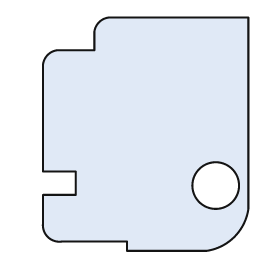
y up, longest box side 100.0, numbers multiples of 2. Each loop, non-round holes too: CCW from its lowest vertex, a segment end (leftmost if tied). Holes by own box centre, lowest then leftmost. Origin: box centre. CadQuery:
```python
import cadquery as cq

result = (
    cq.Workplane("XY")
    .moveTo(-8.0, -50.0)
    .lineTo(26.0, -50.0)
    .threePointArc((38.0, -44.0), (44.0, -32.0))
    .lineTo(44.0, 50.0)
    .lineTo(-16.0, 50.0)
    .threePointArc((-20.0, 48.0), (-22.0, 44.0))
    .lineTo(-22.0, 36.0)
    .lineTo(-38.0, 36.0)
    .threePointArc((-42.0, 34.0), (-44.0, 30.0))
    .lineTo(-44.0, -16.0)
    .lineTo(-30.0, -16.0)
    .lineTo(-30.0, -26.0)
    .lineTo(-44.0, -26.0)
    .lineTo(-44.0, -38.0)
    .threePointArc((-42.0, -44.0), (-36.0, -46.0))
    .lineTo(-8.0, -46.0)
    .close()
    .moveTo(30.0, -22.0)
    .circle(10.0)
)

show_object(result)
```